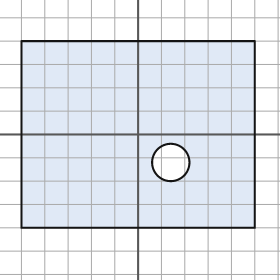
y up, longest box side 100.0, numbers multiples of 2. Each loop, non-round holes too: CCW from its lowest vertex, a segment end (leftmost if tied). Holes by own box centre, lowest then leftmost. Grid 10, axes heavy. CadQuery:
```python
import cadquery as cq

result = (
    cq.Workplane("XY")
    .moveTo(-50.0, -40.0)
    .lineTo(50.0, -40.0)
    .lineTo(50.0, 40.0)
    .lineTo(-50.0, 40.0)
    .close()
    .moveTo(14.0, -12.0)
    .circle(8.0)
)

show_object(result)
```